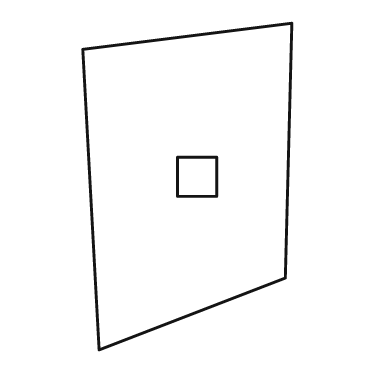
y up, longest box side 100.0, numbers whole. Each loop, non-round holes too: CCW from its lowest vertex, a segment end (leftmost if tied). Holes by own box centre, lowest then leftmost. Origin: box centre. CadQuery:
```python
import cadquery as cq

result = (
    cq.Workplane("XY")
    .moveTo(-27.0, -50.0)
    .lineTo(30.0, -28.0)
    .lineTo(32.0, 50.0)
    .lineTo(-32.0, 42.0)
    .close()
    .moveTo(-3.0, -3.0)
    .lineTo(9.0, -3.0)
    .lineTo(9.0, 9.0)
    .lineTo(-3.0, 9.0)
    .close()
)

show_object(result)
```